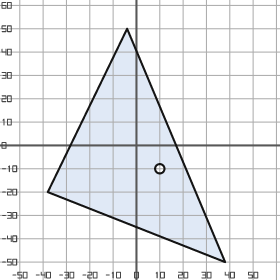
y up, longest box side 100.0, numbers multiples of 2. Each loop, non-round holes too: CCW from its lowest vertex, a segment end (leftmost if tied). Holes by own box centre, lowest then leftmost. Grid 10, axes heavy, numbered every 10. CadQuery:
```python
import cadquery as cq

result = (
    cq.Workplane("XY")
    .moveTo(38.0, -50.0)
    .lineTo(-4.0, 50.0)
    .lineTo(-38.0, -20.0)
    .close()
    .moveTo(10.0, -10.0)
    .circle(2.0)
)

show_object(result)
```